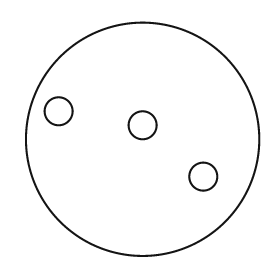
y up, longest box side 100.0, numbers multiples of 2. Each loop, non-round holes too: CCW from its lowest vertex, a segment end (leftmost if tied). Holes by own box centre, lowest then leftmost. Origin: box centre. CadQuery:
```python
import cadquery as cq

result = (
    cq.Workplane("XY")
    .moveTo(0.0, 0.0)
    .circle(50.0)
    .moveTo(26.0, -16.0)
    .circle(6.0)
    .moveTo(0.0, 6.0)
    .circle(6.0)
    .moveTo(-36.0, 12.0)
    .circle(6.0)
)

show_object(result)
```